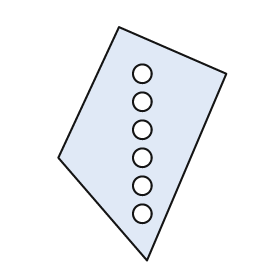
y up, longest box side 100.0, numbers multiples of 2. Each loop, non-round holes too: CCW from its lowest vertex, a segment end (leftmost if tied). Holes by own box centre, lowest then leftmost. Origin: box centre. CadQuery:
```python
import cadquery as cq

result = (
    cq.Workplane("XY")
    .moveTo(2.0, -50.0)
    .lineTo(36.0, 30.0)
    .lineTo(-10.0, 50.0)
    .lineTo(-36.0, -6.0)
    .close()
    .moveTo(0.0, -30.0)
    .circle(4.0)
    .moveTo(0.0, -18.0)
    .circle(4.0)
    .moveTo(0.0, -6.0)
    .circle(4.0)
    .moveTo(0.0, 6.0)
    .circle(4.0)
    .moveTo(0.0, 18.0)
    .circle(4.0)
    .moveTo(0.0, 30.0)
    .circle(4.0)
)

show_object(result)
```